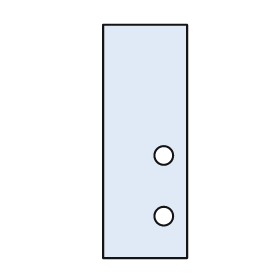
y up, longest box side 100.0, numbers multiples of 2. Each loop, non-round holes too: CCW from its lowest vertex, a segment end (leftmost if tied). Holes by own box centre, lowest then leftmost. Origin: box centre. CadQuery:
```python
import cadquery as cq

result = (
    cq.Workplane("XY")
    .moveTo(-18.0, -50.0)
    .lineTo(18.0, -50.0)
    .lineTo(18.0, 50.0)
    .lineTo(-18.0, 50.0)
    .close()
    .moveTo(8.0, -32.0)
    .circle(4.0)
    .moveTo(8.0, -6.0)
    .circle(4.0)
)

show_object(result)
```